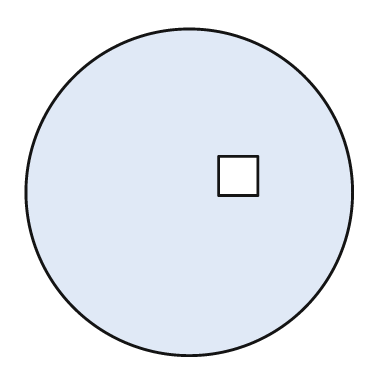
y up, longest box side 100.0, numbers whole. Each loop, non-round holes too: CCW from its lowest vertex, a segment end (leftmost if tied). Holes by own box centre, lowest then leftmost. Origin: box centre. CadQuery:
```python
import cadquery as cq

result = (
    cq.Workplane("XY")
    .moveTo(0.0, 0.0)
    .circle(50.0)
    .moveTo(9.0, -1.0)
    .lineTo(21.0, -1.0)
    .lineTo(21.0, 11.0)
    .lineTo(9.0, 11.0)
    .close()
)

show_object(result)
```